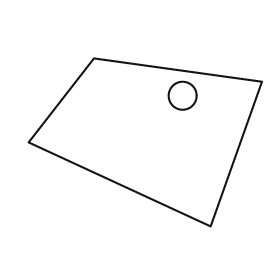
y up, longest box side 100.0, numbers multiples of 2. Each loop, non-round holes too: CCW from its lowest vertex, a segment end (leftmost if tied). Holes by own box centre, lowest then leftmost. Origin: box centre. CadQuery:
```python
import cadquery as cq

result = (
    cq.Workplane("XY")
    .moveTo(28.0, -36.0)
    .lineTo(50.0, 26.0)
    .lineTo(-22.0, 36.0)
    .lineTo(-50.0, 0.0)
    .close()
    .moveTo(16.0, 20.0)
    .circle(6.0)
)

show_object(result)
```